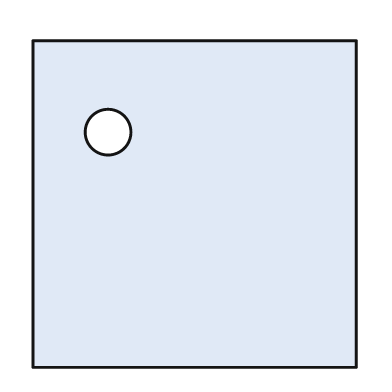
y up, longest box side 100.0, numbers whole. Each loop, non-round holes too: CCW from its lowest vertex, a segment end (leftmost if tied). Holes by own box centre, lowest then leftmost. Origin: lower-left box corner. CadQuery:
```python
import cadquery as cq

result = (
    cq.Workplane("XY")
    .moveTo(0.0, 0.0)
    .lineTo(99.0, 0.0)
    .lineTo(99.0, 100.0)
    .lineTo(0.0, 100.0)
    .close()
    .moveTo(23.0, 72.0)
    .circle(7.0)
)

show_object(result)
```